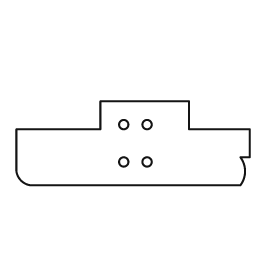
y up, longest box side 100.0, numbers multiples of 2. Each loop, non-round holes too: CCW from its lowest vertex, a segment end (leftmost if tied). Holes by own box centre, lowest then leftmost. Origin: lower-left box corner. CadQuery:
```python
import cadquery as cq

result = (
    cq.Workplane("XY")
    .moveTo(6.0, 0.0)
    .lineTo(96.0, 0.0)
    .threePointArc((98.0, 6.0), (96.0, 12.0))
    .lineTo(100.0, 12.0)
    .lineTo(100.0, 24.0)
    .lineTo(74.0, 24.0)
    .lineTo(74.0, 36.0)
    .lineTo(36.0, 36.0)
    .lineTo(36.0, 24.0)
    .lineTo(0.0, 24.0)
    .lineTo(0.0, 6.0)
    .threePointArc((2.0, 2.0), (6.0, 0.0))
    .close()
    .moveTo(46.0, 10.0)
    .circle(2.0)
    .moveTo(56.0, 10.0)
    .circle(2.0)
    .moveTo(46.0, 26.0)
    .circle(2.0)
    .moveTo(56.0, 26.0)
    .circle(2.0)
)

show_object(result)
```